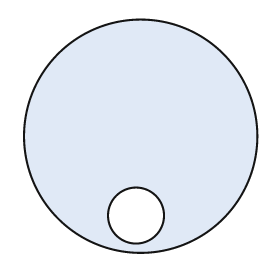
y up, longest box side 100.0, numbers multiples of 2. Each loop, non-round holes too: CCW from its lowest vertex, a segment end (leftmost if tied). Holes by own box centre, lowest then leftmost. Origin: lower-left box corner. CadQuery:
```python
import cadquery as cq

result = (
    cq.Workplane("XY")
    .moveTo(50.0, 50.0)
    .circle(50.0)
    .moveTo(48.0, 16.0)
    .circle(12.0)
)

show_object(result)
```